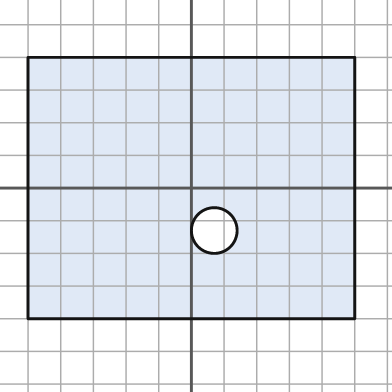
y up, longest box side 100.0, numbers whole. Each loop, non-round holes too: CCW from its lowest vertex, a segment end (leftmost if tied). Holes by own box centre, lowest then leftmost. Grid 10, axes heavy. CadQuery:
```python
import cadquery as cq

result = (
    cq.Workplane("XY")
    .moveTo(-50.0, -40.0)
    .lineTo(50.0, -40.0)
    .lineTo(50.0, 40.0)
    .lineTo(-50.0, 40.0)
    .close()
    .moveTo(7.0, -13.0)
    .circle(7.0)
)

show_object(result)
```